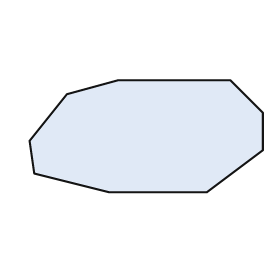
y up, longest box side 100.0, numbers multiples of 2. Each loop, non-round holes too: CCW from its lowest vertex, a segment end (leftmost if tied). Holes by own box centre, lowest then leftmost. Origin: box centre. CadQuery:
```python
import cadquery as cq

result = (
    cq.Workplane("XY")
    .moveTo(-16.0, -24.0)
    .lineTo(26.0, -24.0)
    .lineTo(50.0, -6.0)
    .lineTo(50.0, 10.0)
    .lineTo(36.0, 24.0)
    .lineTo(-12.0, 24.0)
    .lineTo(-34.0, 18.0)
    .lineTo(-50.0, -2.0)
    .lineTo(-48.0, -16.0)
    .close()
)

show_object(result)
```